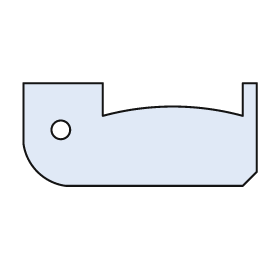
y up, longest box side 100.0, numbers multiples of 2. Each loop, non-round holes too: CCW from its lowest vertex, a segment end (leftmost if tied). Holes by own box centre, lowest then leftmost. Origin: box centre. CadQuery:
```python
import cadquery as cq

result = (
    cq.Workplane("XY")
    .moveTo(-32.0, -22.0)
    .lineTo(44.0, -22.0)
    .lineTo(50.0, -16.0)
    .lineTo(50.0, 22.0)
    .lineTo(44.0, 22.0)
    .lineTo(44.0, 8.0)
    .threePointArc((14.0, 12.0), (-16.0, 8.0))
    .lineTo(-16.0, 22.0)
    .lineTo(-50.0, 22.0)
    .lineTo(-50.0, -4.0)
    .threePointArc((-44.0, -16.0), (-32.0, -22.0))
    .close()
    .moveTo(-34.0, 2.0)
    .circle(4.0)
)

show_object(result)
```